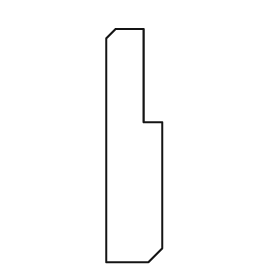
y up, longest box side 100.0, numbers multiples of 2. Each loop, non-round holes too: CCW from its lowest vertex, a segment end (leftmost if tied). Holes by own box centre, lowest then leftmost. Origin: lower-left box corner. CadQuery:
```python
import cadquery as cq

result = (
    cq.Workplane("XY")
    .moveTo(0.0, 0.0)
    .lineTo(18.0, 0.0)
    .lineTo(24.0, 6.0)
    .lineTo(24.0, 60.0)
    .lineTo(16.0, 60.0)
    .lineTo(16.0, 100.0)
    .lineTo(4.0, 100.0)
    .lineTo(0.0, 96.0)
    .close()
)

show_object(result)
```